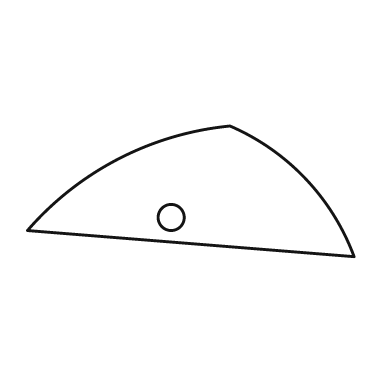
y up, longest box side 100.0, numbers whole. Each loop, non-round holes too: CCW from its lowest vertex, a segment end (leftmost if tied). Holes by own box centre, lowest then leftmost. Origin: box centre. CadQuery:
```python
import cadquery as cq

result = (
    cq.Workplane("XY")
    .moveTo(50.0, -20.0)
    .threePointArc((35.0, 4.0), (12.0, 20.0))
    .threePointArc((-22.0, 10.0), (-50.0, -12.0))
    .close()
    .moveTo(-6.0, -8.0)
    .circle(4.0)
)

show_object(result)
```